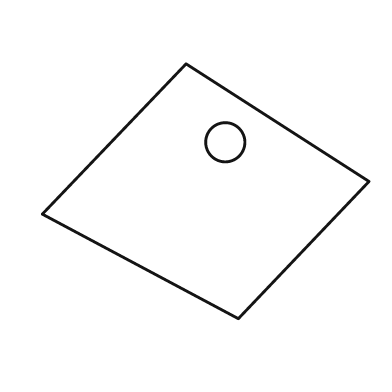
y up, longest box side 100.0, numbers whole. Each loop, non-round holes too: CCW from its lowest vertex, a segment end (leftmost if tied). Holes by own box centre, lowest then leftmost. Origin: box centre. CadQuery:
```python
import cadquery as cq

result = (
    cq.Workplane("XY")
    .moveTo(10.0, -39.0)
    .lineTo(50.0, 3.0)
    .lineTo(-6.0, 39.0)
    .lineTo(-50.0, -7.0)
    .close()
    .moveTo(6.0, 15.0)
    .circle(6.0)
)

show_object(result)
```